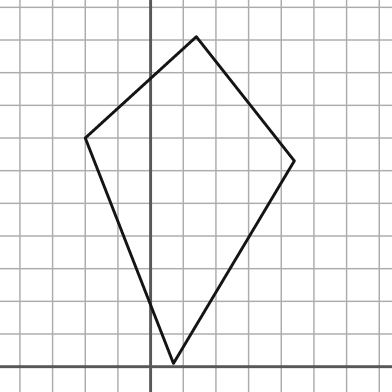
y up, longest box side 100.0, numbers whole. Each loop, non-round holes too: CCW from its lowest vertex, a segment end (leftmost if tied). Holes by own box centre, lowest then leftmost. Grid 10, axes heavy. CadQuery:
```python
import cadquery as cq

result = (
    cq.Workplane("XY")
    .moveTo(7.0, 1.0)
    .lineTo(44.0, 63.0)
    .lineTo(14.0, 101.0)
    .lineTo(-20.0, 70.0)
    .close()
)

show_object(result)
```